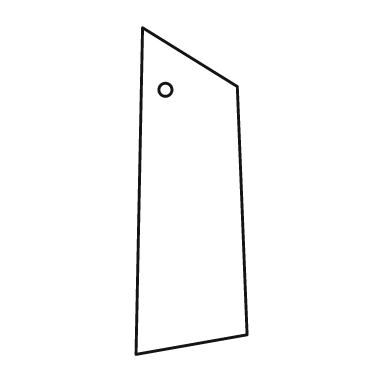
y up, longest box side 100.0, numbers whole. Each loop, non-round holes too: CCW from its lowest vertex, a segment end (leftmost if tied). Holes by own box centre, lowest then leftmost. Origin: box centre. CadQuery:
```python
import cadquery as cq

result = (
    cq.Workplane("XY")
    .moveTo(-17.0, -50.0)
    .lineTo(17.0, -44.0)
    .lineTo(14.0, 32.0)
    .lineTo(-15.0, 50.0)
    .close()
    .moveTo(-8.0, 31.0)
    .circle(2.0)
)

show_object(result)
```